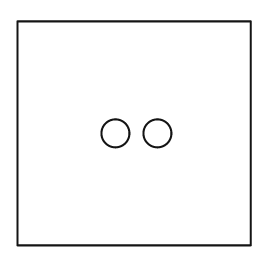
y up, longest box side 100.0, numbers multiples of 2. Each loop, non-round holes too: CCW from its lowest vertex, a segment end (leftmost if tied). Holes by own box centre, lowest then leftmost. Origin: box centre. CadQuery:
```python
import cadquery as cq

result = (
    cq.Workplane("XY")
    .moveTo(-50.0, -48.0)
    .lineTo(50.0, -48.0)
    .lineTo(50.0, 48.0)
    .lineTo(-50.0, 48.0)
    .close()
    .moveTo(-8.0, 0.0)
    .circle(6.0)
    .moveTo(10.0, 0.0)
    .circle(6.0)
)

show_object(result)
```